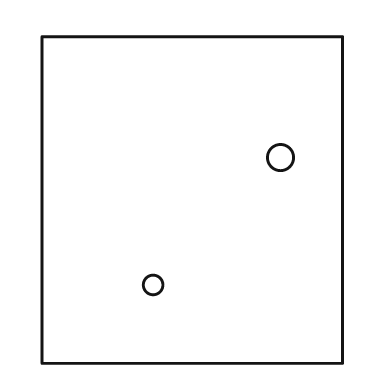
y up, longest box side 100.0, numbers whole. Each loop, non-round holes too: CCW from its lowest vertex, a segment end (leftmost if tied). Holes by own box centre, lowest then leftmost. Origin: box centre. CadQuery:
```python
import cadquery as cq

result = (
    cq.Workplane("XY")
    .moveTo(-46.0, -50.0)
    .lineTo(46.0, -50.0)
    .lineTo(46.0, 50.0)
    .lineTo(-46.0, 50.0)
    .close()
    .moveTo(-12.0, -26.0)
    .circle(3.0)
    .moveTo(27.0, 13.0)
    .circle(4.0)
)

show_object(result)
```